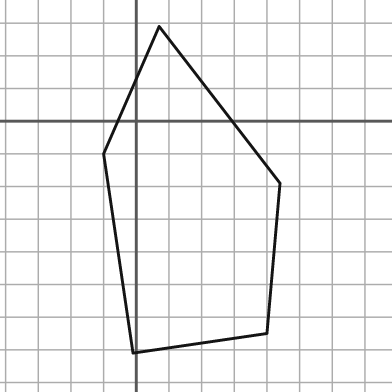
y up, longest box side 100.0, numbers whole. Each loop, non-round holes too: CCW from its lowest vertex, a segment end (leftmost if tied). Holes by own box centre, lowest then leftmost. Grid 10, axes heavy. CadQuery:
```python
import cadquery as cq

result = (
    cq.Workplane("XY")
    .moveTo(-1.0, -71.0)
    .lineTo(40.0, -65.0)
    .lineTo(44.0, -19.0)
    .lineTo(7.0, 29.0)
    .lineTo(-10.0, -10.0)
    .close()
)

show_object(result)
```